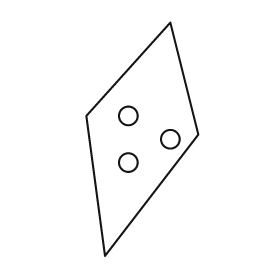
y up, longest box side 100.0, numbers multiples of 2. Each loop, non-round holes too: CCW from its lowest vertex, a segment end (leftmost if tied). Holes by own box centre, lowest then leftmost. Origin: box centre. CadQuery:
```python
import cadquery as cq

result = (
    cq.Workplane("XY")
    .moveTo(-16.0, -50.0)
    .lineTo(24.0, 2.0)
    .lineTo(12.0, 50.0)
    .lineTo(-24.0, 10.0)
    .close()
    .moveTo(-6.0, -10.0)
    .circle(4.0)
    .moveTo(12.0, 0.0)
    .circle(4.0)
    .moveTo(-6.0, 10.0)
    .circle(4.0)
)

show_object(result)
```